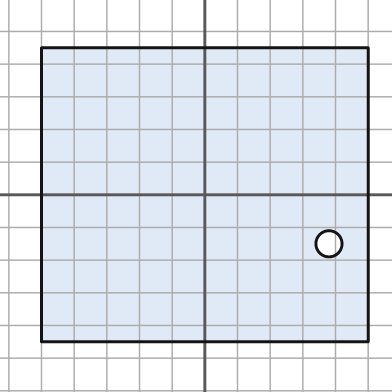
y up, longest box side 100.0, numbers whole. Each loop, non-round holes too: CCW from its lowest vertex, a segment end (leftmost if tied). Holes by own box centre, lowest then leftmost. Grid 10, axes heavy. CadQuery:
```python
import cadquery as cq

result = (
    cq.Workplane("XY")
    .moveTo(-50.0, -45.0)
    .lineTo(50.0, -45.0)
    .lineTo(50.0, 45.0)
    .lineTo(-50.0, 45.0)
    .close()
    .moveTo(38.0, -15.0)
    .circle(4.0)
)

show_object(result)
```